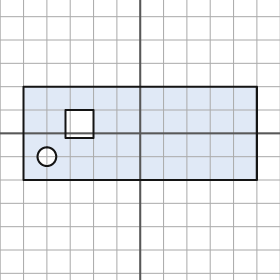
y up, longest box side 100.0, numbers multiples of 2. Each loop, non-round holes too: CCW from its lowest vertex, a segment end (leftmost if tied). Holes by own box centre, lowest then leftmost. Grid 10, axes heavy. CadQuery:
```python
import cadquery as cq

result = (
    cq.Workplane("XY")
    .moveTo(-50.0, -20.0)
    .lineTo(50.0, -20.0)
    .lineTo(50.0, 20.0)
    .lineTo(-50.0, 20.0)
    .close()
    .moveTo(-40.0, -10.0)
    .circle(4.0)
    .moveTo(-32.0, -2.0)
    .lineTo(-20.0, -2.0)
    .lineTo(-20.0, 10.0)
    .lineTo(-32.0, 10.0)
    .close()
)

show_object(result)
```